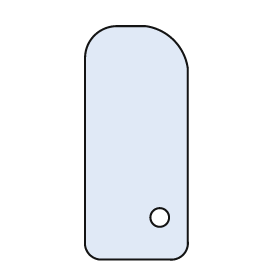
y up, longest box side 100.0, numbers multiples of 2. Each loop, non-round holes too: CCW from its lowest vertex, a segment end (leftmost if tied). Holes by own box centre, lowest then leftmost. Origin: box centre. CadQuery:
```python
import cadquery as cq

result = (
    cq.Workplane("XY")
    .moveTo(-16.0, -50.0)
    .lineTo(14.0, -50.0)
    .threePointArc((20.0, -48.0), (22.0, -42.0))
    .lineTo(22.0, 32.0)
    .threePointArc((16.0, 44.0), (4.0, 50.0))
    .lineTo(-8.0, 50.0)
    .threePointArc((-18.0, 46.0), (-22.0, 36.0))
    .lineTo(-22.0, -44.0)
    .threePointArc((-20.0, -48.0), (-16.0, -50.0))
    .close()
    .moveTo(10.0, -32.0)
    .circle(4.0)
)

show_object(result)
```